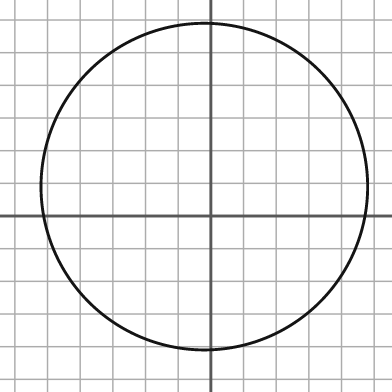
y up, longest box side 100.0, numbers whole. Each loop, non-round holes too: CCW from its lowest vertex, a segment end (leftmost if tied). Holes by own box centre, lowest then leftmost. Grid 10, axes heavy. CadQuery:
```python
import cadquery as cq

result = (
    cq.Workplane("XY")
    .moveTo(-2.0, 9.0)
    .circle(50.0)
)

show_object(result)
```